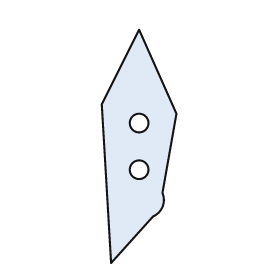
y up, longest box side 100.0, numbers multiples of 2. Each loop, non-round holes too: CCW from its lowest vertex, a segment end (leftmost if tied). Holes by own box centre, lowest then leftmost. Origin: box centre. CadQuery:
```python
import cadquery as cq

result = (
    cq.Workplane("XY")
    .moveTo(-12.0, -50.0)
    .lineTo(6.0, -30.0)
    .threePointArc((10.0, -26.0), (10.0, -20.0))
    .lineTo(16.0, 14.0)
    .lineTo(0.0, 50.0)
    .lineTo(-16.0, 18.0)
    .close()
    .moveTo(0.0, -10.0)
    .circle(4.0)
    .moveTo(0.0, 10.0)
    .circle(4.0)
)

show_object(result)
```